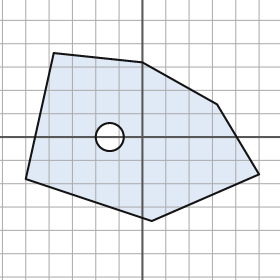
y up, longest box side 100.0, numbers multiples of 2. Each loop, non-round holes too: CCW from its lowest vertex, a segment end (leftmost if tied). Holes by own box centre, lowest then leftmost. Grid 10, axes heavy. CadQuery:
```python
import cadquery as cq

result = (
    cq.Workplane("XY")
    .moveTo(4.0, -36.0)
    .lineTo(50.0, -16.0)
    .lineTo(32.0, 14.0)
    .lineTo(0.0, 32.0)
    .lineTo(-38.0, 36.0)
    .lineTo(-50.0, -18.0)
    .close()
    .moveTo(-14.0, 0.0)
    .circle(6.0)
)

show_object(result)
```